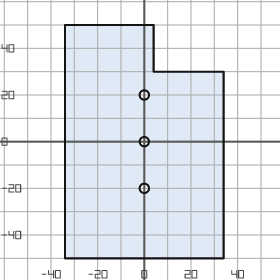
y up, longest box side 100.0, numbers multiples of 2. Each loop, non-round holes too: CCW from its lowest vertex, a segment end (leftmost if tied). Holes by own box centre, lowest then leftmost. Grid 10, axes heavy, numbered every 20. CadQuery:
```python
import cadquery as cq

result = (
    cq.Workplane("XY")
    .moveTo(-34.0, -50.0)
    .lineTo(34.0, -50.0)
    .lineTo(34.0, 30.0)
    .lineTo(4.0, 30.0)
    .lineTo(4.0, 50.0)
    .lineTo(-34.0, 50.0)
    .close()
    .moveTo(0.0, -20.0)
    .circle(2.0)
    .moveTo(0.0, 0.0)
    .circle(2.0)
    .moveTo(0.0, 20.0)
    .circle(2.0)
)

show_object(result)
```